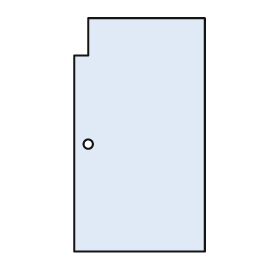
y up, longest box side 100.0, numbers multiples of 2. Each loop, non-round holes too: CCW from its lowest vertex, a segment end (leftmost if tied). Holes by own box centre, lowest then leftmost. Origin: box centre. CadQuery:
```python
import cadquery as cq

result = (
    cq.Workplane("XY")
    .moveTo(-28.0, -50.0)
    .lineTo(28.0, -50.0)
    .lineTo(28.0, 50.0)
    .lineTo(-22.0, 50.0)
    .lineTo(-22.0, 34.0)
    .lineTo(-28.0, 34.0)
    .close()
    .moveTo(-22.0, -4.0)
    .circle(2.0)
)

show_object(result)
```